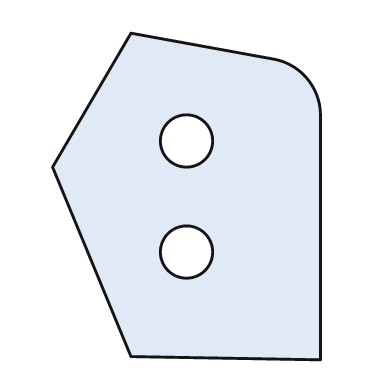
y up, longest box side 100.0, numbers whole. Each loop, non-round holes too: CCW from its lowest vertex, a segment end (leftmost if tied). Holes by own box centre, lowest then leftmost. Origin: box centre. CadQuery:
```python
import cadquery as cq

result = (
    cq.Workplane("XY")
    .moveTo(41.0, -50.0)
    .lineTo(41.0, 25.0)
    .threePointArc((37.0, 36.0), (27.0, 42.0))
    .lineTo(-17.0, 50.0)
    .lineTo(-41.0, 9.0)
    .lineTo(-17.0, -49.0)
    .close()
    .moveTo(0.0, -17.0)
    .circle(8.0)
    .moveTo(0.0, 17.0)
    .circle(8.0)
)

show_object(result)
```